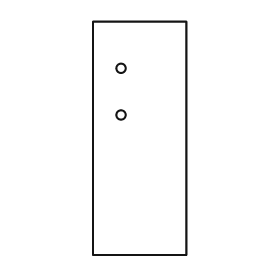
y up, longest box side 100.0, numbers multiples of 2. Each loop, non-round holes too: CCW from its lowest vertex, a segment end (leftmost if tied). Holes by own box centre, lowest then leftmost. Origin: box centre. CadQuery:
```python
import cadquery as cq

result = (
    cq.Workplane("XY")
    .moveTo(-20.0, -50.0)
    .lineTo(20.0, -50.0)
    .lineTo(20.0, 50.0)
    .lineTo(-20.0, 50.0)
    .close()
    .moveTo(-8.0, 10.0)
    .circle(2.0)
    .moveTo(-8.0, 30.0)
    .circle(2.0)
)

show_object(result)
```